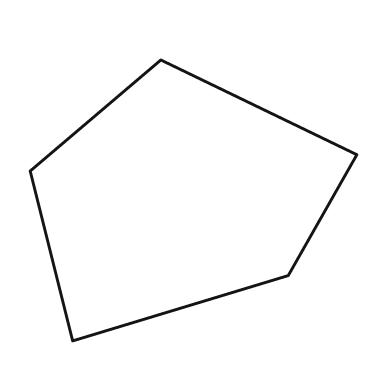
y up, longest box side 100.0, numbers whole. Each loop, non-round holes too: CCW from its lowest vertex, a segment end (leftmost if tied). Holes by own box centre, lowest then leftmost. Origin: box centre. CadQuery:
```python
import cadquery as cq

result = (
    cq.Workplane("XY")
    .moveTo(-37.0, -43.0)
    .lineTo(29.0, -23.0)
    .lineTo(50.0, 14.0)
    .lineTo(-10.0, 43.0)
    .lineTo(-50.0, 9.0)
    .close()
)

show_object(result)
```